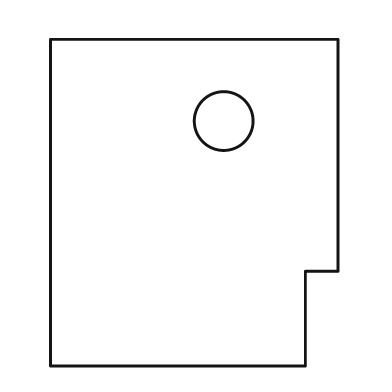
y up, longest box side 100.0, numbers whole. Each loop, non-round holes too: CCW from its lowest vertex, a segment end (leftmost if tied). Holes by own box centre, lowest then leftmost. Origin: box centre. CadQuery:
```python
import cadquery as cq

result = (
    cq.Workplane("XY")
    .moveTo(-44.0, -50.0)
    .lineTo(34.0, -50.0)
    .lineTo(34.0, -21.0)
    .lineTo(44.0, -21.0)
    .lineTo(44.0, 50.0)
    .lineTo(-44.0, 50.0)
    .close()
    .moveTo(9.0, 25.0)
    .circle(9.0)
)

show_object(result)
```